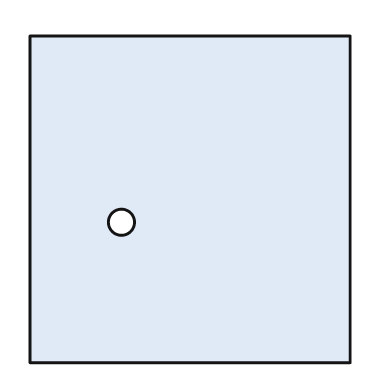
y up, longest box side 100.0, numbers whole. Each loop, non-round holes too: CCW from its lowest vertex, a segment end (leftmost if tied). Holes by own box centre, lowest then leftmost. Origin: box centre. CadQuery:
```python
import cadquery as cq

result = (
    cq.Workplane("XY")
    .moveTo(-49.0, -50.0)
    .lineTo(49.0, -50.0)
    .lineTo(49.0, 50.0)
    .lineTo(-49.0, 50.0)
    .close()
    .moveTo(-21.0, -7.0)
    .circle(4.0)
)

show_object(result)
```